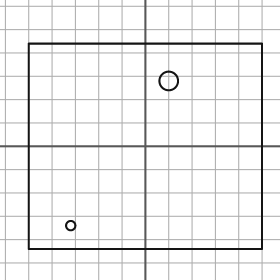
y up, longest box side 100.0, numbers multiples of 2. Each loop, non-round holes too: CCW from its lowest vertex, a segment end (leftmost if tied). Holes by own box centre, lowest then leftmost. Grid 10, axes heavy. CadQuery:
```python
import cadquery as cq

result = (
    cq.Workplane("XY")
    .moveTo(-50.0, -44.0)
    .lineTo(50.0, -44.0)
    .lineTo(50.0, 44.0)
    .lineTo(-50.0, 44.0)
    .close()
    .moveTo(-32.0, -34.0)
    .circle(2.0)
    .moveTo(10.0, 28.0)
    .circle(4.0)
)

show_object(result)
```